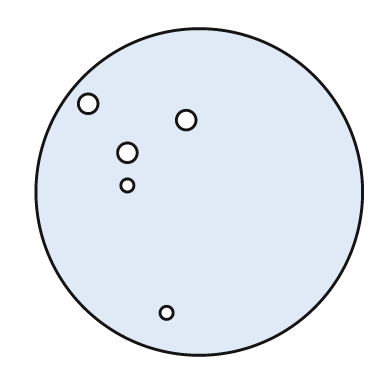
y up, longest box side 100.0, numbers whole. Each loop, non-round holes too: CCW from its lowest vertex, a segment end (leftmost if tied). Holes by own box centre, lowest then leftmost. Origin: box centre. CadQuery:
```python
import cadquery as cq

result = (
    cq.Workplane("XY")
    .moveTo(0.0, 0.0)
    .circle(50.0)
    .moveTo(-10.0, -37.0)
    .circle(2.0)
    .moveTo(-22.0, 2.0)
    .circle(2.0)
    .moveTo(-22.0, 12.0)
    .circle(3.0)
    .moveTo(-4.0, 22.0)
    .circle(3.0)
    .moveTo(-34.0, 27.0)
    .circle(3.0)
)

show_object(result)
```